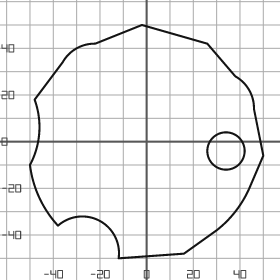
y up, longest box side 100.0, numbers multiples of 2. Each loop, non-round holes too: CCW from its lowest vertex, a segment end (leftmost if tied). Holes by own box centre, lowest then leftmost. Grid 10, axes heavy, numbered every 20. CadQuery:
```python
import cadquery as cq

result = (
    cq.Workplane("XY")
    .moveTo(-12.0, -50.0)
    .lineTo(16.0, -48.0)
    .lineTo(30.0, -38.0)
    .threePointArc((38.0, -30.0), (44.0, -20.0))
    .lineTo(50.0, -6.0)
    .lineTo(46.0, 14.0)
    .threePointArc((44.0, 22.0), (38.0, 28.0))
    .lineTo(26.0, 42.0)
    .lineTo(-2.0, 50.0)
    .lineTo(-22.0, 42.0)
    .threePointArc((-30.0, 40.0), (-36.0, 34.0))
    .lineTo(-48.0, 18.0)
    .threePointArc((-46.0, 4.0), (-50.0, -10.0))
    .threePointArc((-46.0, -24.0), (-38.0, -36.0))
    .threePointArc((-20.0, -34.0), (-12.0, -50.0))
    .close()
    .moveTo(34.0, -4.0)
    .circle(8.0)
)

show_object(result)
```